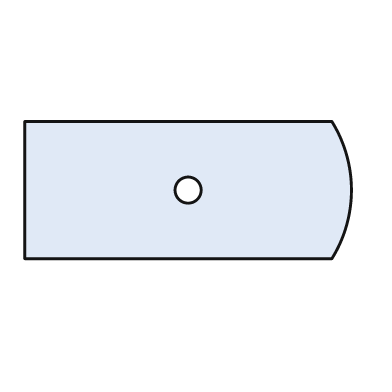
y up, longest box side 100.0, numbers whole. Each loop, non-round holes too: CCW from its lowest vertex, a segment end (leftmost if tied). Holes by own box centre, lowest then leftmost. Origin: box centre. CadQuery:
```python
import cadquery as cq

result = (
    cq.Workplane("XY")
    .moveTo(-50.0, -21.0)
    .lineTo(44.0, -21.0)
    .threePointArc((50.0, 0.0), (44.0, 21.0))
    .lineTo(-50.0, 21.0)
    .close()
    .moveTo(0.0, 0.0)
    .circle(4.0)
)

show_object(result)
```